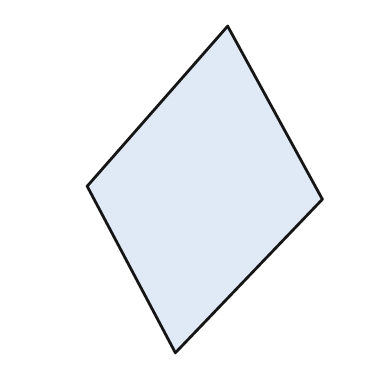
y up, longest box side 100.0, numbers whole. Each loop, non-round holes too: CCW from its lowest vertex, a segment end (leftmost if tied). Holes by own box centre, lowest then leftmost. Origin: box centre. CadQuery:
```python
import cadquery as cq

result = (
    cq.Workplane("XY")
    .moveTo(-9.0, -50.0)
    .lineTo(36.0, -3.0)
    .lineTo(7.0, 50.0)
    .lineTo(-36.0, 1.0)
    .close()
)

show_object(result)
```